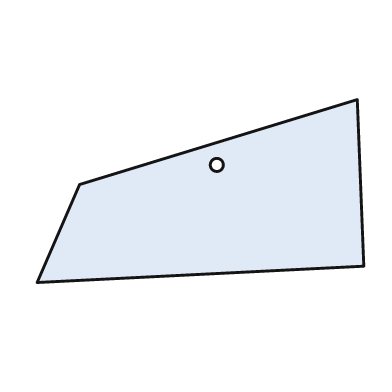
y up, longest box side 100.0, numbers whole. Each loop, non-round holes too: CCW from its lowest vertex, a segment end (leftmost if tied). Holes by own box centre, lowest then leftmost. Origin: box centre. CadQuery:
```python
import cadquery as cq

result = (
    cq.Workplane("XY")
    .moveTo(-50.0, -28.0)
    .lineTo(50.0, -23.0)
    .lineTo(48.0, 28.0)
    .lineTo(-37.0, 2.0)
    .close()
    .moveTo(5.0, 8.0)
    .circle(2.0)
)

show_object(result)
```